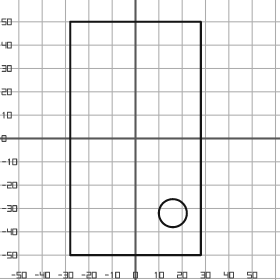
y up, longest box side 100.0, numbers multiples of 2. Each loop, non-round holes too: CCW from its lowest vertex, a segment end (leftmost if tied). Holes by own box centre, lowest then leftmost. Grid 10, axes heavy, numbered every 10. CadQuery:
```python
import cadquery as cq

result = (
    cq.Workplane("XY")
    .moveTo(-28.0, -50.0)
    .lineTo(28.0, -50.0)
    .lineTo(28.0, 50.0)
    .lineTo(-28.0, 50.0)
    .close()
    .moveTo(16.0, -32.0)
    .circle(6.0)
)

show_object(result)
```